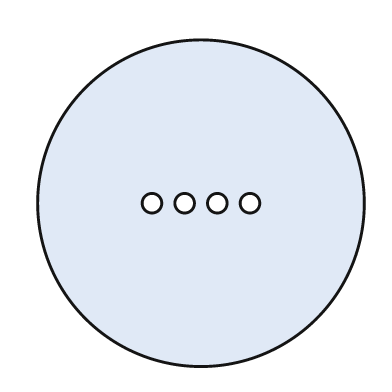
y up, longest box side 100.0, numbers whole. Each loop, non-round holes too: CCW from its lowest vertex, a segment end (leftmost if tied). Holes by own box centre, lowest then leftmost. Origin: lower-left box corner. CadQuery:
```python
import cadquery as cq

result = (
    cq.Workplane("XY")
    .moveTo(50.0, 50.0)
    .circle(50.0)
    .moveTo(35.0, 50.0)
    .circle(3.0)
    .moveTo(45.0, 50.0)
    .circle(3.0)
    .moveTo(55.0, 50.0)
    .circle(3.0)
    .moveTo(65.0, 50.0)
    .circle(3.0)
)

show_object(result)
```